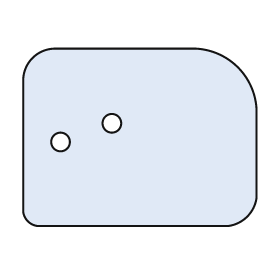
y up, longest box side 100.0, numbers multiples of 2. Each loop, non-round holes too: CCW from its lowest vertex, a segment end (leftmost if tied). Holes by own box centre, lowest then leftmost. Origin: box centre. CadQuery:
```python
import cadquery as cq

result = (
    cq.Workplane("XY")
    .moveTo(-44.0, -38.0)
    .lineTo(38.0, -38.0)
    .threePointArc((46.0, -34.0), (50.0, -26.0))
    .lineTo(50.0, 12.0)
    .threePointArc((42.0, 30.0), (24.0, 38.0))
    .lineTo(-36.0, 38.0)
    .threePointArc((-46.0, 34.0), (-50.0, 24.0))
    .lineTo(-50.0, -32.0)
    .threePointArc((-48.0, -36.0), (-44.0, -38.0))
    .close()
    .moveTo(-34.0, -2.0)
    .circle(4.0)
    .moveTo(-12.0, 6.0)
    .circle(4.0)
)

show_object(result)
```